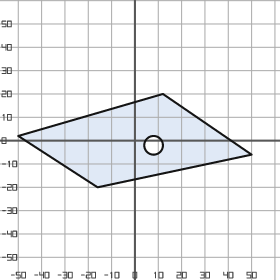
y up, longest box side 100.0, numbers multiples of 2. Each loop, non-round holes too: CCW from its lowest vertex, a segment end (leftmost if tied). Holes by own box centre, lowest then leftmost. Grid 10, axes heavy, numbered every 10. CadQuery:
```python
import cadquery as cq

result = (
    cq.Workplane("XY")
    .moveTo(-16.0, -20.0)
    .lineTo(50.0, -6.0)
    .lineTo(12.0, 20.0)
    .lineTo(-50.0, 2.0)
    .close()
    .moveTo(8.0, -2.0)
    .circle(4.0)
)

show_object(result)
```